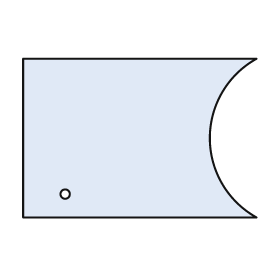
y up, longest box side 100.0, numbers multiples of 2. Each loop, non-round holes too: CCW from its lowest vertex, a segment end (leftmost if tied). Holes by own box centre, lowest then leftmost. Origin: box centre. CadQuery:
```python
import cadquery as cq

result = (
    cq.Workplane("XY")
    .moveTo(-50.0, -34.0)
    .lineTo(50.0, -34.0)
    .threePointArc((30.0, 0.0), (50.0, 34.0))
    .lineTo(-50.0, 34.0)
    .close()
    .moveTo(-32.0, -24.0)
    .circle(2.0)
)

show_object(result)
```